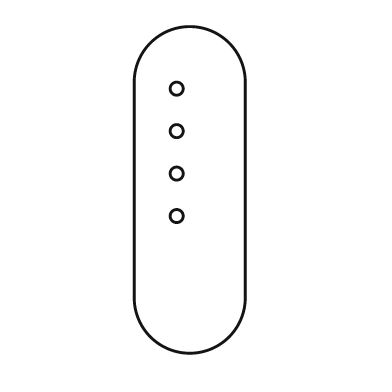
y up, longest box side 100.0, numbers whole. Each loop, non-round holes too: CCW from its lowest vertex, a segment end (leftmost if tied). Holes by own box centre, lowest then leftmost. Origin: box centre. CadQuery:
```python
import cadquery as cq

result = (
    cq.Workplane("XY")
    .moveTo(-17.0, -33.0)
    .threePointArc((0.0, -50.0), (17.0, -33.0))
    .lineTo(17.0, 33.0)
    .threePointArc((0.0, 50.0), (-17.0, 33.0))
    .close()
    .moveTo(-4.0, -8.0)
    .circle(2.0)
    .moveTo(-4.0, 5.0)
    .circle(2.0)
    .moveTo(-4.0, 18.0)
    .circle(2.0)
    .moveTo(-4.0, 31.0)
    .circle(2.0)
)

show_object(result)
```